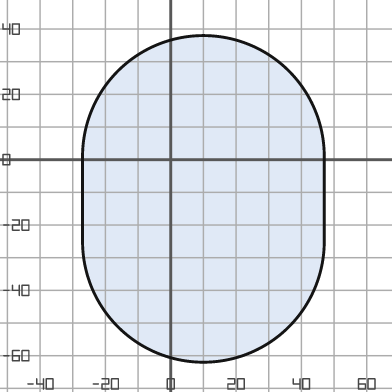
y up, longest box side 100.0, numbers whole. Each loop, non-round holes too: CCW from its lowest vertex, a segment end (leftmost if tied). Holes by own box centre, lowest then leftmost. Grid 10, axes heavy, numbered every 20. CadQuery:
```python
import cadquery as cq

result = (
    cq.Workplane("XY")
    .moveTo(-27.0, -25.0)
    .threePointArc((10.0, -62.0), (47.0, -25.0))
    .lineTo(47.0, 1.0)
    .threePointArc((10.0, 38.0), (-27.0, 1.0))
    .close()
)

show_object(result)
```